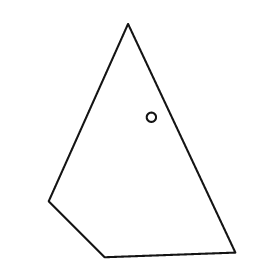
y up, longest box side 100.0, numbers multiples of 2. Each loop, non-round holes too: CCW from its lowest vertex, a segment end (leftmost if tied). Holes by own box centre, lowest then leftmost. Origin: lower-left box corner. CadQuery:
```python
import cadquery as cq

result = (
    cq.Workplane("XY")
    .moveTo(24.0, 0.0)
    .lineTo(80.0, 2.0)
    .lineTo(34.0, 100.0)
    .lineTo(0.0, 24.0)
    .close()
    .moveTo(44.0, 60.0)
    .circle(2.0)
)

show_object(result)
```